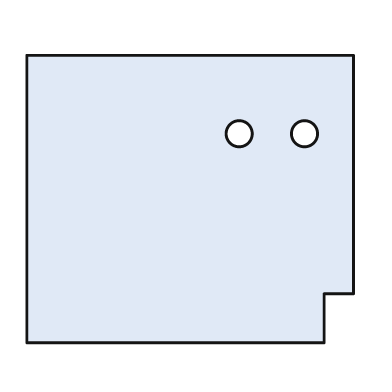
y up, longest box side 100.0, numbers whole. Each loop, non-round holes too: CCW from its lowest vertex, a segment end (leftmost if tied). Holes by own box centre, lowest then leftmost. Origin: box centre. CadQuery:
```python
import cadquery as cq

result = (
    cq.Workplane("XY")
    .moveTo(-50.0, -44.0)
    .lineTo(41.0, -44.0)
    .lineTo(41.0, -29.0)
    .lineTo(50.0, -29.0)
    .lineTo(50.0, 44.0)
    .lineTo(-50.0, 44.0)
    .close()
    .moveTo(15.0, 20.0)
    .circle(4.0)
    .moveTo(35.0, 20.0)
    .circle(4.0)
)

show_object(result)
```